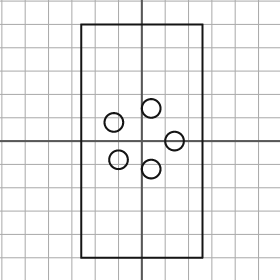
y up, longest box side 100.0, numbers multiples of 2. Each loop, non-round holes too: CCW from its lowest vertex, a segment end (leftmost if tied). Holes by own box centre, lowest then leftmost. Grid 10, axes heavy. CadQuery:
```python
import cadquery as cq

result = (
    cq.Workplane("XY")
    .moveTo(-26.0, -50.0)
    .lineTo(26.0, -50.0)
    .lineTo(26.0, 50.0)
    .lineTo(-26.0, 50.0)
    .close()
    .moveTo(4.0, -12.0)
    .circle(4.0)
    .moveTo(-10.0, -8.0)
    .circle(4.0)
    .moveTo(14.0, 0.0)
    .circle(4.0)
    .moveTo(-12.0, 8.0)
    .circle(4.0)
    .moveTo(4.0, 14.0)
    .circle(4.0)
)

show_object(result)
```